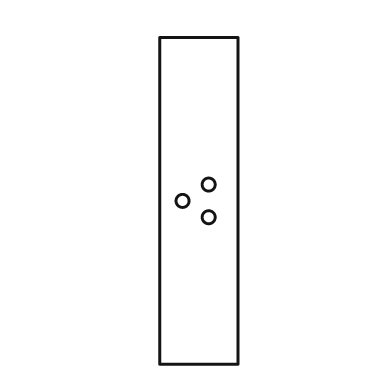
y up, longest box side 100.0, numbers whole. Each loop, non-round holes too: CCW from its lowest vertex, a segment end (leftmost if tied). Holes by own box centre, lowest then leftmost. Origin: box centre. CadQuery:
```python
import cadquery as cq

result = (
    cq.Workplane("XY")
    .moveTo(-12.0, -50.0)
    .lineTo(12.0, -50.0)
    .lineTo(12.0, 50.0)
    .lineTo(-12.0, 50.0)
    .close()
    .moveTo(3.0, -5.0)
    .circle(2.0)
    .moveTo(-5.0, 0.0)
    .circle(2.0)
    .moveTo(3.0, 5.0)
    .circle(2.0)
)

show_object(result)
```